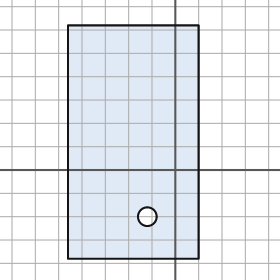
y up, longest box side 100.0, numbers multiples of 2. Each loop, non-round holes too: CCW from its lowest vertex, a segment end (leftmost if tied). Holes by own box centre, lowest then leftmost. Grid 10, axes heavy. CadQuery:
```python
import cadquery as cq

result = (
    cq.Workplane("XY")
    .moveTo(-46.0, -38.0)
    .lineTo(10.0, -38.0)
    .lineTo(10.0, 62.0)
    .lineTo(-46.0, 62.0)
    .close()
    .moveTo(-12.0, -20.0)
    .circle(4.0)
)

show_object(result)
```